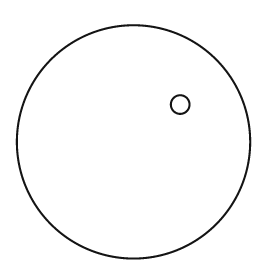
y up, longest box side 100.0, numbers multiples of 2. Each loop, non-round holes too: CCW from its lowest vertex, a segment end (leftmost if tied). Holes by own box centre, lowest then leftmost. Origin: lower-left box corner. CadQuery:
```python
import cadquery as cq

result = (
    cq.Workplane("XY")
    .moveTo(50.0, 50.0)
    .circle(50.0)
    .moveTo(70.0, 66.0)
    .circle(4.0)
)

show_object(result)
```